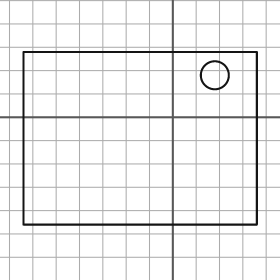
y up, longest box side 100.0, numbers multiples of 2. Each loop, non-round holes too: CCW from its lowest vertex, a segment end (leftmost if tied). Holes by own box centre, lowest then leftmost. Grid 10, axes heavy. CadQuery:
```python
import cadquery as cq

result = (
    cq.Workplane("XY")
    .moveTo(-64.0, -46.0)
    .lineTo(36.0, -46.0)
    .lineTo(36.0, 28.0)
    .lineTo(-64.0, 28.0)
    .close()
    .moveTo(18.0, 18.0)
    .circle(6.0)
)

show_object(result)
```